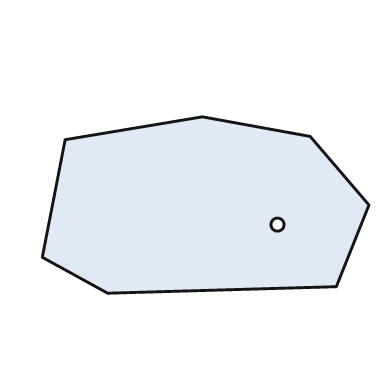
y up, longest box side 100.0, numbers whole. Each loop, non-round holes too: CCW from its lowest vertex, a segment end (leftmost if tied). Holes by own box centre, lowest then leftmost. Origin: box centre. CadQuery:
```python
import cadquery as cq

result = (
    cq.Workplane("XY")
    .moveTo(-30.0, -27.0)
    .lineTo(40.0, -25.0)
    .lineTo(50.0, 0.0)
    .lineTo(32.0, 21.0)
    .lineTo(-1.0, 27.0)
    .lineTo(-43.0, 20.0)
    .lineTo(-50.0, -16.0)
    .close()
    .moveTo(22.0, -6.0)
    .circle(2.0)
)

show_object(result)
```